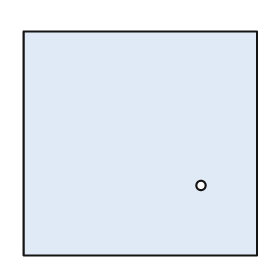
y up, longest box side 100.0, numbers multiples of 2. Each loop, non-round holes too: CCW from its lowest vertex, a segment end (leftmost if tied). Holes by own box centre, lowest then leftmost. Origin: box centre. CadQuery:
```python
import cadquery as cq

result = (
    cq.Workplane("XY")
    .moveTo(-50.0, -48.0)
    .lineTo(50.0, -48.0)
    .lineTo(50.0, 48.0)
    .lineTo(-50.0, 48.0)
    .close()
    .moveTo(26.0, -18.0)
    .circle(2.0)
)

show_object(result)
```